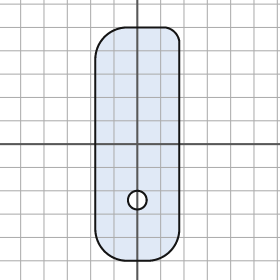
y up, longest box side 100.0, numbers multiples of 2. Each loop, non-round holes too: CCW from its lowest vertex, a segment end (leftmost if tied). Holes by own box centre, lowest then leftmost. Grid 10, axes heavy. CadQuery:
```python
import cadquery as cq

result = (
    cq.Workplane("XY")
    .moveTo(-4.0, -50.0)
    .lineTo(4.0, -50.0)
    .threePointArc((14.0, -46.0), (18.0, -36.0))
    .lineTo(18.0, 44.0)
    .threePointArc((16.0, 48.0), (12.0, 50.0))
    .lineTo(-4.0, 50.0)
    .threePointArc((-14.0, 46.0), (-18.0, 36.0))
    .lineTo(-18.0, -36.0)
    .threePointArc((-14.0, -46.0), (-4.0, -50.0))
    .close()
    .moveTo(0.0, -24.0)
    .circle(4.0)
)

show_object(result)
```